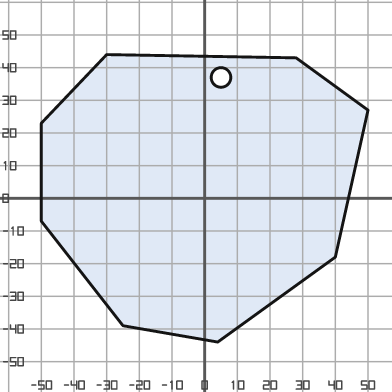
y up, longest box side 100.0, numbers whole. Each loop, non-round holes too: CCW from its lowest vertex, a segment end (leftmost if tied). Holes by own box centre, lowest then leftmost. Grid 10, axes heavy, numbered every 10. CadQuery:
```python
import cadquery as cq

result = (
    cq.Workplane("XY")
    .moveTo(4.0, -44.0)
    .lineTo(40.0, -18.0)
    .lineTo(50.0, 27.0)
    .lineTo(28.0, 43.0)
    .lineTo(-30.0, 44.0)
    .lineTo(-50.0, 23.0)
    .lineTo(-50.0, -7.0)
    .lineTo(-25.0, -39.0)
    .close()
    .moveTo(5.0, 37.0)
    .circle(3.0)
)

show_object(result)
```